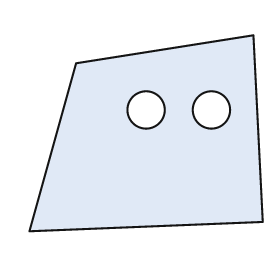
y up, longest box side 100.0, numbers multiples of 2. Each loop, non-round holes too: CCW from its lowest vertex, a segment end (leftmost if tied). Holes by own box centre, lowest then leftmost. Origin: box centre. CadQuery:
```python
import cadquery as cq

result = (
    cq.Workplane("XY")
    .moveTo(-50.0, -42.0)
    .lineTo(50.0, -38.0)
    .lineTo(46.0, 42.0)
    .lineTo(-30.0, 30.0)
    .close()
    .moveTo(0.0, 10.0)
    .circle(8.0)
    .moveTo(28.0, 10.0)
    .circle(8.0)
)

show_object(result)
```